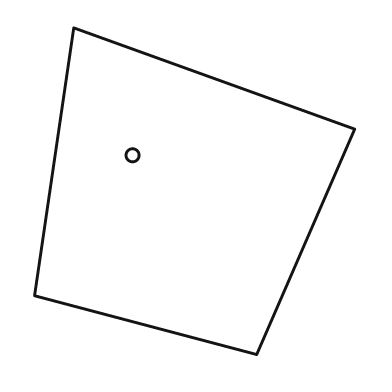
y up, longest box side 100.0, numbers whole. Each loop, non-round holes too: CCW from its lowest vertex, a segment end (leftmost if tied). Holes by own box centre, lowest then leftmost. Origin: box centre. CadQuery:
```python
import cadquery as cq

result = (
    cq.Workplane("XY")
    .moveTo(19.0, -50.0)
    .lineTo(49.0, 19.0)
    .lineTo(-37.0, 50.0)
    .lineTo(-49.0, -32.0)
    .close()
    .moveTo(-19.0, 11.0)
    .circle(2.0)
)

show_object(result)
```